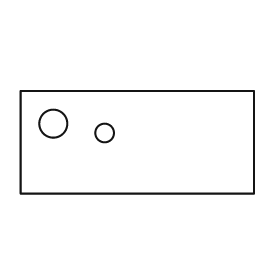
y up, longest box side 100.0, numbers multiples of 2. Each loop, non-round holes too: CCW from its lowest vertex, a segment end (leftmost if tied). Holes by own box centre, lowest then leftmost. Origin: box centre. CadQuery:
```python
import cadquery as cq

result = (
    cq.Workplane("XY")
    .moveTo(-50.0, -22.0)
    .lineTo(50.0, -22.0)
    .lineTo(50.0, 22.0)
    .lineTo(-50.0, 22.0)
    .close()
    .moveTo(-14.0, 4.0)
    .circle(4.0)
    .moveTo(-36.0, 8.0)
    .circle(6.0)
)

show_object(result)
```